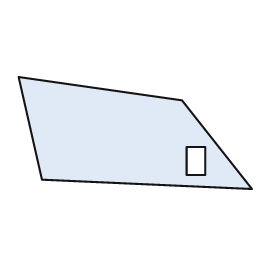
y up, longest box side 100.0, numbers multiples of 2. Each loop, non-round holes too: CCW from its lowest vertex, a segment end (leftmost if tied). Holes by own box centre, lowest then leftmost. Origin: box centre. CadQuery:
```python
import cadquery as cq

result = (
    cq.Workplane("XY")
    .moveTo(50.0, -24.0)
    .lineTo(20.0, 14.0)
    .lineTo(-50.0, 24.0)
    .lineTo(-40.0, -20.0)
    .close()
    .moveTo(22.0, -18.0)
    .lineTo(30.0, -18.0)
    .lineTo(30.0, -6.0)
    .lineTo(22.0, -6.0)
    .close()
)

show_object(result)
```